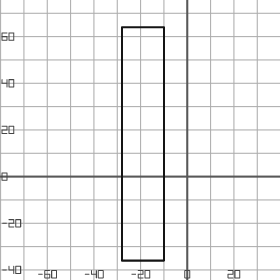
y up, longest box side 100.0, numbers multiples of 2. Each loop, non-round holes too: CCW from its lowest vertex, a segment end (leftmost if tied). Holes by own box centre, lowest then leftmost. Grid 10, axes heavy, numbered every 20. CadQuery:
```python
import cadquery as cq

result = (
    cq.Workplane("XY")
    .moveTo(-28.0, -36.0)
    .lineTo(-10.0, -36.0)
    .lineTo(-10.0, 64.0)
    .lineTo(-28.0, 64.0)
    .close()
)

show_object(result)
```